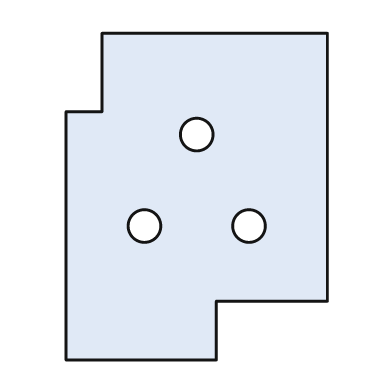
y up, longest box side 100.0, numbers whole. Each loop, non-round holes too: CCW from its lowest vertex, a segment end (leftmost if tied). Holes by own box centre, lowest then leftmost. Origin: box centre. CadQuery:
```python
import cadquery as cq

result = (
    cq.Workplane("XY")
    .moveTo(-40.0, -50.0)
    .lineTo(6.0, -50.0)
    .lineTo(6.0, -32.0)
    .lineTo(40.0, -32.0)
    .lineTo(40.0, 50.0)
    .lineTo(-29.0, 50.0)
    .lineTo(-29.0, 26.0)
    .lineTo(-40.0, 26.0)
    .close()
    .moveTo(-16.0, -9.0)
    .circle(5.0)
    .moveTo(16.0, -9.0)
    .circle(5.0)
    .moveTo(0.0, 19.0)
    .circle(5.0)
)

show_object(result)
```